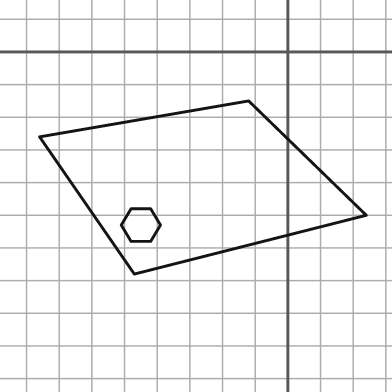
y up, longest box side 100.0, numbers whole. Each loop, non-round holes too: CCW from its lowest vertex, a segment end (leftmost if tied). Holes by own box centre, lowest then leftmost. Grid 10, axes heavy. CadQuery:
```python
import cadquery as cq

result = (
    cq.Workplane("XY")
    .moveTo(-47.0, -68.0)
    .lineTo(24.0, -50.0)
    .lineTo(-12.0, -15.0)
    .lineTo(-76.0, -26.0)
    .close()
    .moveTo(-48.0, -58.0)
    .lineTo(-42.0, -58.0)
    .lineTo(-39.0, -53.0)
    .lineTo(-42.0, -48.0)
    .lineTo(-48.0, -48.0)
    .lineTo(-51.0, -53.0)
    .close()
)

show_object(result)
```